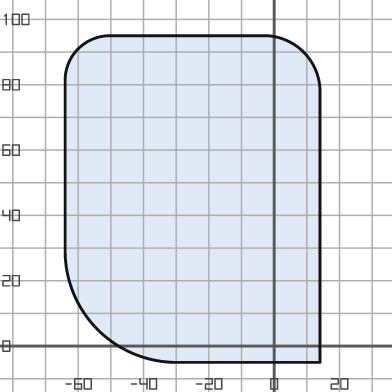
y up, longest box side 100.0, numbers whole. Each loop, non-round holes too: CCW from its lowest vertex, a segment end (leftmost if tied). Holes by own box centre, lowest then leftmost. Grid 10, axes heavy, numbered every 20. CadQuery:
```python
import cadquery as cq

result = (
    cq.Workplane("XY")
    .moveTo(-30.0, -5.0)
    .lineTo(14.0, -5.0)
    .lineTo(14.0, 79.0)
    .threePointArc((9.0, 90.0), (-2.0, 95.0))
    .lineTo(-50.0, 95.0)
    .threePointArc((-60.0, 91.0), (-64.0, 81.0))
    .lineTo(-64.0, 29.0)
    .threePointArc((-54.0, 5.0), (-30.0, -5.0))
    .close()
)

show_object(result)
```